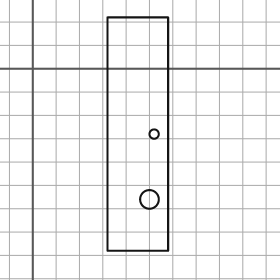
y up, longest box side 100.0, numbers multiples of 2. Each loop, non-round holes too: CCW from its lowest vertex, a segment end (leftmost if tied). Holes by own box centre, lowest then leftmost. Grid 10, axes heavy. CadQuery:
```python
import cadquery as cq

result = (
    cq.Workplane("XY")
    .moveTo(32.0, -78.0)
    .lineTo(58.0, -78.0)
    .lineTo(58.0, 22.0)
    .lineTo(32.0, 22.0)
    .close()
    .moveTo(50.0, -56.0)
    .circle(4.0)
    .moveTo(52.0, -28.0)
    .circle(2.0)
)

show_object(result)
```